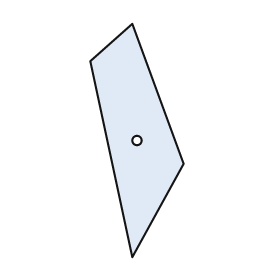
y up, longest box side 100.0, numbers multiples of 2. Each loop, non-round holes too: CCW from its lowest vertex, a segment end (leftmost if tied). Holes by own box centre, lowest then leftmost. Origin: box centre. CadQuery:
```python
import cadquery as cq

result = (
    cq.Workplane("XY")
    .moveTo(-2.0, -50.0)
    .lineTo(20.0, -10.0)
    .lineTo(-2.0, 50.0)
    .lineTo(-20.0, 34.0)
    .close()
    .moveTo(0.0, 0.0)
    .circle(2.0)
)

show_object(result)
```